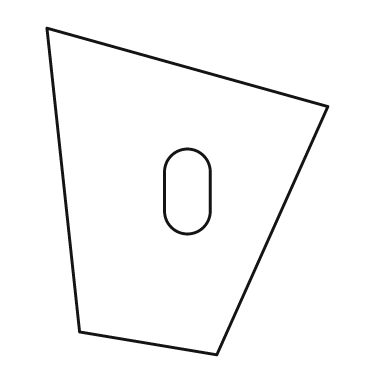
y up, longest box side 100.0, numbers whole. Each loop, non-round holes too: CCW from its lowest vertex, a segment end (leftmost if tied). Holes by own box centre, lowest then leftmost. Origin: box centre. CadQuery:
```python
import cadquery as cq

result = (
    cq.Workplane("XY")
    .moveTo(9.0, -50.0)
    .lineTo(43.0, 26.0)
    .lineTo(-43.0, 50.0)
    .lineTo(-33.0, -43.0)
    .close()
    .moveTo(-7.0, -6.0)
    .threePointArc((0.0, -13.0), (7.0, -6.0))
    .lineTo(7.0, 6.0)
    .threePointArc((0.0, 13.0), (-7.0, 6.0))
    .close()
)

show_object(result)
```